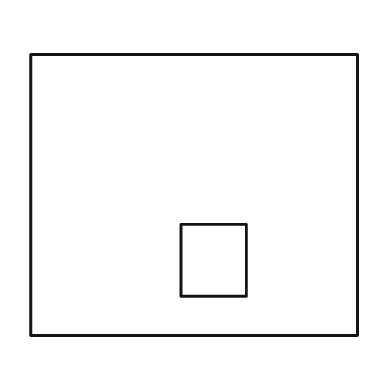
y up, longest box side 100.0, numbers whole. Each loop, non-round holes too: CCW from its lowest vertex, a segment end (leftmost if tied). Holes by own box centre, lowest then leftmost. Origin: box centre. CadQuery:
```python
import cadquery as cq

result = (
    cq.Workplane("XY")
    .moveTo(-50.0, -43.0)
    .lineTo(50.0, -43.0)
    .lineTo(50.0, 43.0)
    .lineTo(-50.0, 43.0)
    .close()
    .moveTo(-4.0, -31.0)
    .lineTo(16.0, -31.0)
    .lineTo(16.0, -9.0)
    .lineTo(-4.0, -9.0)
    .close()
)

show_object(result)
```